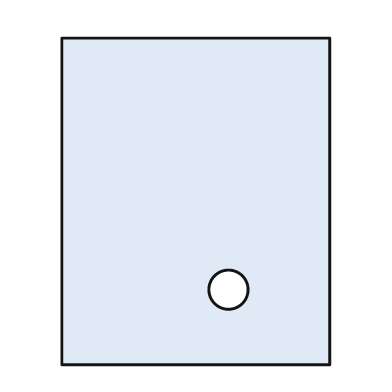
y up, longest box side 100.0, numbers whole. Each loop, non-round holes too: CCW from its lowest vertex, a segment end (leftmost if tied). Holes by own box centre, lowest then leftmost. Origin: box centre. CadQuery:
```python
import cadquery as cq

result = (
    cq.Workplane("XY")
    .moveTo(-41.0, -50.0)
    .lineTo(41.0, -50.0)
    .lineTo(41.0, 50.0)
    .lineTo(-41.0, 50.0)
    .close()
    .moveTo(10.0, -27.0)
    .circle(6.0)
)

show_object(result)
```